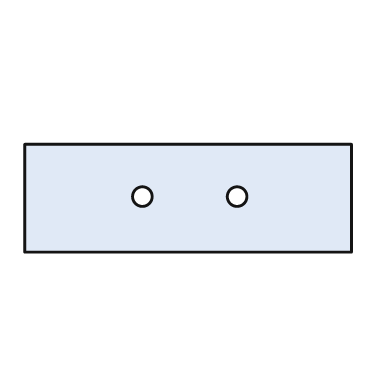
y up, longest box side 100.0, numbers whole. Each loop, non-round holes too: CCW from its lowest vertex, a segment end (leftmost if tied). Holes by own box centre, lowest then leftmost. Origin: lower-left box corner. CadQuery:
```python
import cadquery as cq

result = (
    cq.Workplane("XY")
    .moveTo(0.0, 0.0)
    .lineTo(100.0, 0.0)
    .lineTo(100.0, 33.0)
    .lineTo(0.0, 33.0)
    .close()
    .moveTo(36.0, 17.0)
    .circle(3.0)
    .moveTo(65.0, 17.0)
    .circle(3.0)
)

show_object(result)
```